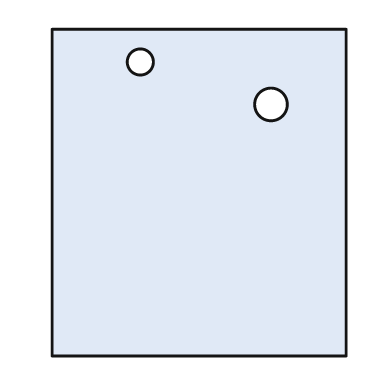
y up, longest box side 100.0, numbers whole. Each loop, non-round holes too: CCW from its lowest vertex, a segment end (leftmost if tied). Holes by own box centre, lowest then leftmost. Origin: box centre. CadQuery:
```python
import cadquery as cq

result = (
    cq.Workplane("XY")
    .moveTo(-45.0, -50.0)
    .lineTo(45.0, -50.0)
    .lineTo(45.0, 50.0)
    .lineTo(-45.0, 50.0)
    .close()
    .moveTo(22.0, 27.0)
    .circle(5.0)
    .moveTo(-18.0, 40.0)
    .circle(4.0)
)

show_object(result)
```